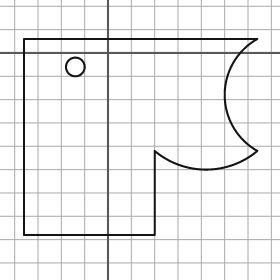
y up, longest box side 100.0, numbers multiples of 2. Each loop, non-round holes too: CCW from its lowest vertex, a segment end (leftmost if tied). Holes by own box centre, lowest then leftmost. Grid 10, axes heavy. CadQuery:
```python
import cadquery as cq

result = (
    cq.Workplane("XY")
    .moveTo(-36.0, -78.0)
    .lineTo(20.0, -78.0)
    .lineTo(20.0, -42.0)
    .threePointArc((42.0, -50.0), (64.0, -42.0))
    .threePointArc((50.0, -18.0), (64.0, 6.0))
    .lineTo(-36.0, 6.0)
    .close()
    .moveTo(-14.0, -6.0)
    .circle(4.0)
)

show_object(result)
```